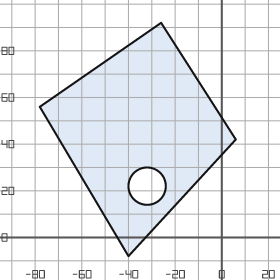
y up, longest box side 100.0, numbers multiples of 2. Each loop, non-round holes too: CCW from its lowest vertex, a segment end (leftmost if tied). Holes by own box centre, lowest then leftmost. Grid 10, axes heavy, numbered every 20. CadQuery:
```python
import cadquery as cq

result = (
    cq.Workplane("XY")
    .moveTo(-40.0, -8.0)
    .lineTo(6.0, 42.0)
    .lineTo(-26.0, 92.0)
    .lineTo(-78.0, 56.0)
    .close()
    .moveTo(-32.0, 22.0)
    .circle(8.0)
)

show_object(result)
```